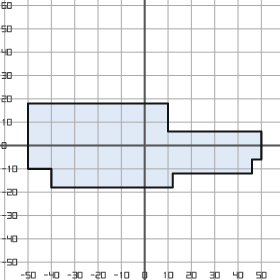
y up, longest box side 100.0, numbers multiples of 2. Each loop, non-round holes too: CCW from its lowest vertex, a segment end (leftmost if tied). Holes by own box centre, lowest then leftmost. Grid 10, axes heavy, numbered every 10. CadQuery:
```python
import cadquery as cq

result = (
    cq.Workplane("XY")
    .moveTo(-40.0, -18.0)
    .lineTo(12.0, -18.0)
    .lineTo(12.0, -12.0)
    .lineTo(46.0, -12.0)
    .lineTo(46.0, -6.0)
    .lineTo(50.0, -6.0)
    .lineTo(50.0, 6.0)
    .lineTo(10.0, 6.0)
    .lineTo(10.0, 18.0)
    .lineTo(-50.0, 18.0)
    .lineTo(-50.0, -10.0)
    .lineTo(-40.0, -10.0)
    .close()
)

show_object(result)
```